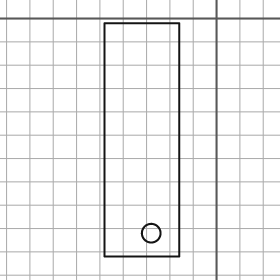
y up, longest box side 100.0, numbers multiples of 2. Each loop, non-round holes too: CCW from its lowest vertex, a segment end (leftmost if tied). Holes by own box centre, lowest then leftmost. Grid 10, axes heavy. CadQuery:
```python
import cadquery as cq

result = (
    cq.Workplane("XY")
    .moveTo(-48.0, -102.0)
    .lineTo(-16.0, -102.0)
    .lineTo(-16.0, -2.0)
    .lineTo(-48.0, -2.0)
    .close()
    .moveTo(-28.0, -92.0)
    .circle(4.0)
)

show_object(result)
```